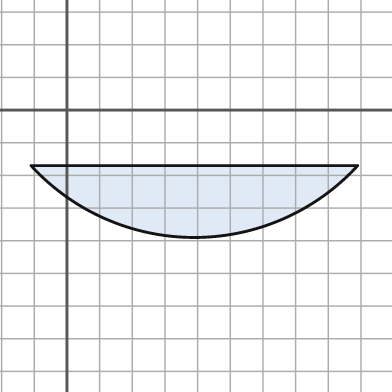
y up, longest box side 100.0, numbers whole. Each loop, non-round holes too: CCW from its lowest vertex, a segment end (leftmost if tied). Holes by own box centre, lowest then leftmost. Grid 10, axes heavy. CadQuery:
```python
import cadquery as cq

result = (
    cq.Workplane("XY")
    .moveTo(-11.0, -17.0)
    .threePointArc((39.0, -39.0), (89.0, -17.0))
    .close()
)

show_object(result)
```